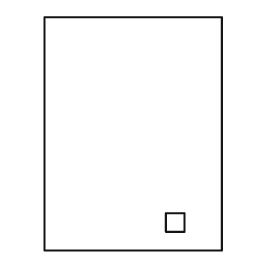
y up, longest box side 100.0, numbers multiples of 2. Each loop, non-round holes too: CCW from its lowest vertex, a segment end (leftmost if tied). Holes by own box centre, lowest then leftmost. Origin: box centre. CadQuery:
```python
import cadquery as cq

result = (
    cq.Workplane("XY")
    .moveTo(-38.0, -50.0)
    .lineTo(38.0, -50.0)
    .lineTo(38.0, 50.0)
    .lineTo(-38.0, 50.0)
    .close()
    .moveTo(14.0, -42.0)
    .lineTo(22.0, -42.0)
    .lineTo(22.0, -34.0)
    .lineTo(14.0, -34.0)
    .close()
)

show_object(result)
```